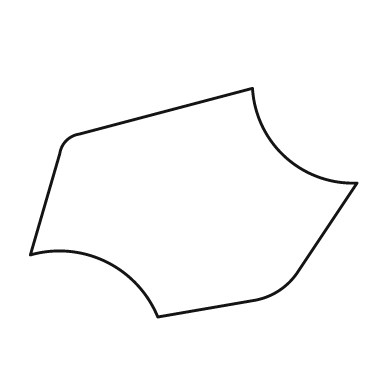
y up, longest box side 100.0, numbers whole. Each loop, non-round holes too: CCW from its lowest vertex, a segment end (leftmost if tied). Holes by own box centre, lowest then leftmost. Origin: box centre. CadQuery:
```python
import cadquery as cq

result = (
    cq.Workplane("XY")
    .moveTo(-11.0, -35.0)
    .lineTo(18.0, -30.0)
    .threePointArc((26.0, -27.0), (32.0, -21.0))
    .lineTo(50.0, 6.0)
    .threePointArc((28.0, 14.0), (18.0, 35.0))
    .lineTo(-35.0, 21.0)
    .threePointArc((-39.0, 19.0), (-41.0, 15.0))
    .lineTo(-50.0, -16.0)
    .threePointArc((-27.0, -18.0), (-11.0, -35.0))
    .close()
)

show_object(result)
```